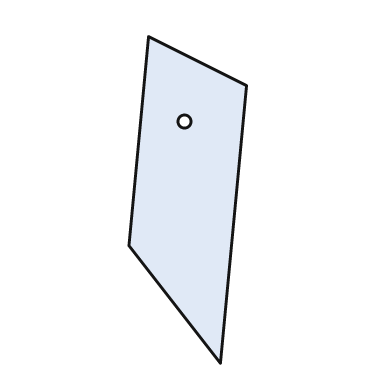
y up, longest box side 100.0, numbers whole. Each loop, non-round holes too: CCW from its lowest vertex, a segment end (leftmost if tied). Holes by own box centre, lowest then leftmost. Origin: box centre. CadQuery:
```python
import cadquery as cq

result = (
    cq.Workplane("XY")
    .moveTo(10.0, -50.0)
    .lineTo(18.0, 35.0)
    .lineTo(-12.0, 50.0)
    .lineTo(-18.0, -14.0)
    .close()
    .moveTo(-1.0, 24.0)
    .circle(2.0)
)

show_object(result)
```